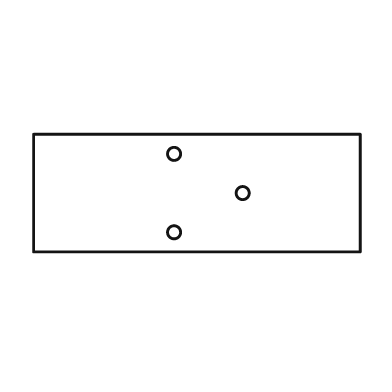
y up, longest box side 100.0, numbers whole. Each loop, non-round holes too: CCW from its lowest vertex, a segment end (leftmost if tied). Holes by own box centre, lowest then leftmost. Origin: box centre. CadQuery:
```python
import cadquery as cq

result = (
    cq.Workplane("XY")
    .moveTo(-50.0, -18.0)
    .lineTo(50.0, -18.0)
    .lineTo(50.0, 18.0)
    .lineTo(-50.0, 18.0)
    .close()
    .moveTo(-7.0, -12.0)
    .circle(2.0)
    .moveTo(14.0, 0.0)
    .circle(2.0)
    .moveTo(-7.0, 12.0)
    .circle(2.0)
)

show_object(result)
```